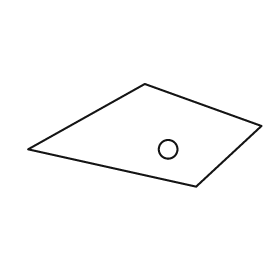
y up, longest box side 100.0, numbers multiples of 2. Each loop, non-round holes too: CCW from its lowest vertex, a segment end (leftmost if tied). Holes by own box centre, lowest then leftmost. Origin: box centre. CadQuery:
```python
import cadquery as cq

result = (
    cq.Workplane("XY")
    .moveTo(22.0, -22.0)
    .lineTo(50.0, 4.0)
    .lineTo(0.0, 22.0)
    .lineTo(-50.0, -6.0)
    .close()
    .moveTo(10.0, -6.0)
    .circle(4.0)
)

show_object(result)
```